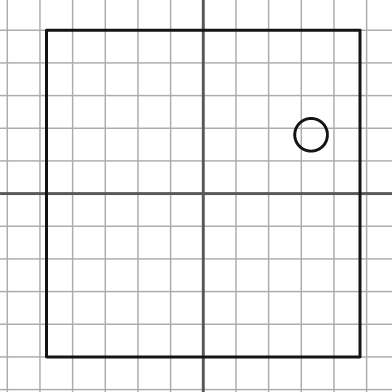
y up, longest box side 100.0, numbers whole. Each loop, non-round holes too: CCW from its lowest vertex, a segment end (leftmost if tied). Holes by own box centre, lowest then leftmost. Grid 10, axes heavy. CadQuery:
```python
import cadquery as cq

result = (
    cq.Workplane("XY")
    .moveTo(-48.0, -50.0)
    .lineTo(48.0, -50.0)
    .lineTo(48.0, 50.0)
    .lineTo(-48.0, 50.0)
    .close()
    .moveTo(33.0, 18.0)
    .circle(5.0)
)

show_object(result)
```